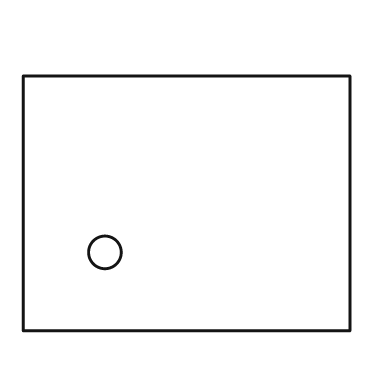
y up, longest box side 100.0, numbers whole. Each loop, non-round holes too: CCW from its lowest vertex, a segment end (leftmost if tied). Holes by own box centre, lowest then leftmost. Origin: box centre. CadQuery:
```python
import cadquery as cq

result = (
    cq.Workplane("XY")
    .moveTo(-50.0, -39.0)
    .lineTo(50.0, -39.0)
    .lineTo(50.0, 39.0)
    .lineTo(-50.0, 39.0)
    .close()
    .moveTo(-25.0, -15.0)
    .circle(5.0)
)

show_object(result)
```